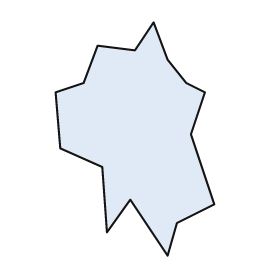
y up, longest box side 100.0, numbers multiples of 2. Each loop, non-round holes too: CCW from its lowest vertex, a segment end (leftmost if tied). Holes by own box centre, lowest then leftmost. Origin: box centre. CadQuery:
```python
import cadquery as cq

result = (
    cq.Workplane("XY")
    .moveTo(14.0, -50.0)
    .lineTo(18.0, -36.0)
    .lineTo(34.0, -28.0)
    .lineTo(24.0, 2.0)
    .lineTo(30.0, 20.0)
    .lineTo(22.0, 24.0)
    .lineTo(14.0, 34.0)
    .lineTo(8.0, 50.0)
    .lineTo(0.0, 38.0)
    .lineTo(-16.0, 40.0)
    .lineTo(-22.0, 24.0)
    .lineTo(-34.0, 20.0)
    .lineTo(-32.0, -4.0)
    .lineTo(-14.0, -12.0)
    .lineTo(-12.0, -40.0)
    .lineTo(-2.0, -26.0)
    .close()
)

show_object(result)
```